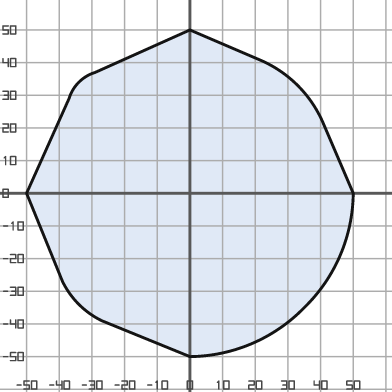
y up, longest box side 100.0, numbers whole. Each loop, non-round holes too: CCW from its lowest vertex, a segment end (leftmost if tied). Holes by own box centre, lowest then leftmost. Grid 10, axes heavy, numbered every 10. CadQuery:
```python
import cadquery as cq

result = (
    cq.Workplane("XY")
    .moveTo(0.0, -50.0)
    .threePointArc((19.0, -46.0), (35.0, -35.0))
    .threePointArc((46.0, -19.0), (50.0, 0.0))
    .lineTo(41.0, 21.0)
    .threePointArc((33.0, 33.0), (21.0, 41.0))
    .lineTo(0.0, 50.0)
    .lineTo(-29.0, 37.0)
    .threePointArc((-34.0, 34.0), (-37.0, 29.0))
    .lineTo(-50.0, 0.0)
    .lineTo(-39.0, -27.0)
    .threePointArc((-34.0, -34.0), (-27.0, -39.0))
    .close()
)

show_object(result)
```